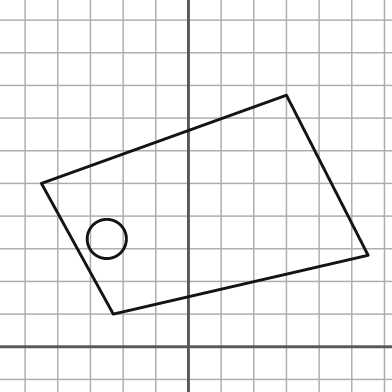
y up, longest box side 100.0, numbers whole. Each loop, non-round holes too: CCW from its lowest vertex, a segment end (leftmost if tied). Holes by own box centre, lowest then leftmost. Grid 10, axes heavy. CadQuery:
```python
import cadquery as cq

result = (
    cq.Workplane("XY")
    .moveTo(-23.0, 10.0)
    .lineTo(55.0, 28.0)
    .lineTo(30.0, 77.0)
    .lineTo(-45.0, 50.0)
    .close()
    .moveTo(-25.0, 33.0)
    .circle(6.0)
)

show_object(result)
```